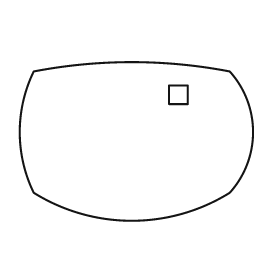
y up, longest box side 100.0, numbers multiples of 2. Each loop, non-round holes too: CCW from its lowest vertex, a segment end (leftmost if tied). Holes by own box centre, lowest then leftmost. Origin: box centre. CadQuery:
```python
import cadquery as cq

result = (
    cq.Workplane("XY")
    .moveTo(-44.0, -22.0)
    .threePointArc((-2.0, -34.0), (40.0, -22.0))
    .threePointArc((50.0, 4.0), (40.0, 30.0))
    .threePointArc((-2.0, 34.0), (-44.0, 30.0))
    .threePointArc((-50.0, 4.0), (-44.0, -22.0))
    .close()
    .moveTo(14.0, 16.0)
    .lineTo(22.0, 16.0)
    .lineTo(22.0, 24.0)
    .lineTo(14.0, 24.0)
    .close()
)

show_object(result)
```